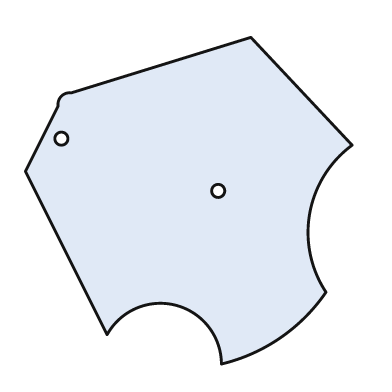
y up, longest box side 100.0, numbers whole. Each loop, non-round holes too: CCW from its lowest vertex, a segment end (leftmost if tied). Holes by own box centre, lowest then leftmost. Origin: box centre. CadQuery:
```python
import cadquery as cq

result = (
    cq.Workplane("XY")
    .moveTo(10.0, -50.0)
    .threePointArc((28.0, -42.0), (42.0, -28.0))
    .threePointArc((37.0, -4.0), (50.0, 17.0))
    .lineTo(19.0, 50.0)
    .lineTo(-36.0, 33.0)
    .threePointArc((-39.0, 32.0), (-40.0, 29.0))
    .lineTo(-50.0, 9.0)
    .lineTo(-25.0, -41.0)
    .threePointArc((-4.0, -32.0), (10.0, -50.0))
    .close()
    .moveTo(9.0, 3.0)
    .circle(2.0)
    .moveTo(-39.0, 19.0)
    .circle(2.0)
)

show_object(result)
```